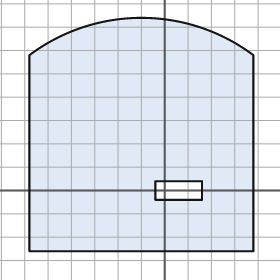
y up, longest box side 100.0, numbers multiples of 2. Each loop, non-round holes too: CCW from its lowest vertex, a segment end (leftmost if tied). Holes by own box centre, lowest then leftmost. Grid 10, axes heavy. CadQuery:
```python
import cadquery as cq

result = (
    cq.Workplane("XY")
    .moveTo(-58.0, -26.0)
    .lineTo(38.0, -26.0)
    .lineTo(38.0, 58.0)
    .threePointArc((-10.0, 74.0), (-58.0, 58.0))
    .close()
    .moveTo(-4.0, -4.0)
    .lineTo(16.0, -4.0)
    .lineTo(16.0, 4.0)
    .lineTo(-4.0, 4.0)
    .close()
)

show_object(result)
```